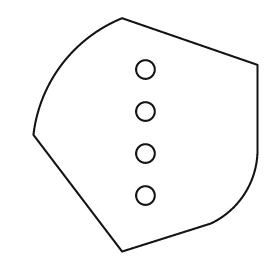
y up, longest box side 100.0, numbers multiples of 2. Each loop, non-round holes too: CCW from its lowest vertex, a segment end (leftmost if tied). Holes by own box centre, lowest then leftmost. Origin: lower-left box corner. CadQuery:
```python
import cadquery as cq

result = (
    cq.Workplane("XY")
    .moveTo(38.0, 0.0)
    .lineTo(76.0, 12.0)
    .threePointArc((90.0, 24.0), (96.0, 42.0))
    .lineTo(96.0, 80.0)
    .lineTo(38.0, 100.0)
    .threePointArc((12.0, 80.0), (0.0, 50.0))
    .close()
    .moveTo(48.0, 24.0)
    .circle(4.0)
    .moveTo(48.0, 42.0)
    .circle(4.0)
    .moveTo(48.0, 60.0)
    .circle(4.0)
    .moveTo(48.0, 78.0)
    .circle(4.0)
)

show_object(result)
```